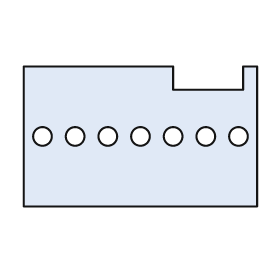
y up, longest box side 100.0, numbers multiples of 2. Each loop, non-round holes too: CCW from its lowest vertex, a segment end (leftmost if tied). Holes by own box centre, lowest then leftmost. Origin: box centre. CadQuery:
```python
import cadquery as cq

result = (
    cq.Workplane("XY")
    .moveTo(-50.0, -30.0)
    .lineTo(50.0, -30.0)
    .lineTo(50.0, 30.0)
    .lineTo(44.0, 30.0)
    .lineTo(44.0, 20.0)
    .lineTo(14.0, 20.0)
    .lineTo(14.0, 30.0)
    .lineTo(-50.0, 30.0)
    .close()
    .moveTo(-42.0, 0.0)
    .circle(4.0)
    .moveTo(-28.0, 0.0)
    .circle(4.0)
    .moveTo(-14.0, 0.0)
    .circle(4.0)
    .moveTo(0.0, 0.0)
    .circle(4.0)
    .moveTo(14.0, 0.0)
    .circle(4.0)
    .moveTo(28.0, 0.0)
    .circle(4.0)
    .moveTo(42.0, 0.0)
    .circle(4.0)
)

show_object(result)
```